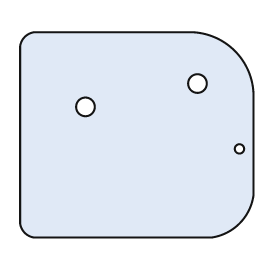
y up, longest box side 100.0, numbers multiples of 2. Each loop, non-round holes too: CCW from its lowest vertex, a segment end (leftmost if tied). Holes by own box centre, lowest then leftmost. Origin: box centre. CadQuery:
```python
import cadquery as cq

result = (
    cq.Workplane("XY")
    .moveTo(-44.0, -44.0)
    .lineTo(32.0, -44.0)
    .threePointArc((44.0, -38.0), (50.0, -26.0))
    .lineTo(50.0, 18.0)
    .threePointArc((42.0, 36.0), (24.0, 44.0))
    .lineTo(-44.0, 44.0)
    .threePointArc((-48.0, 42.0), (-50.0, 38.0))
    .lineTo(-50.0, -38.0)
    .threePointArc((-48.0, -42.0), (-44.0, -44.0))
    .close()
    .moveTo(44.0, -6.0)
    .circle(2.0)
    .moveTo(-22.0, 12.0)
    .circle(4.0)
    .moveTo(26.0, 22.0)
    .circle(4.0)
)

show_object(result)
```